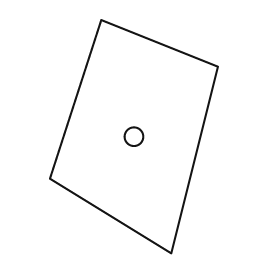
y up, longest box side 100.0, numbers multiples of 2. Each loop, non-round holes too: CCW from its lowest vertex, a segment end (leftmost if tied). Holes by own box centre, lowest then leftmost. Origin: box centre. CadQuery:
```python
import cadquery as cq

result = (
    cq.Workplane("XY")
    .moveTo(16.0, -50.0)
    .lineTo(36.0, 30.0)
    .lineTo(-14.0, 50.0)
    .lineTo(-36.0, -18.0)
    .close()
    .moveTo(0.0, 0.0)
    .circle(4.0)
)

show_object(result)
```